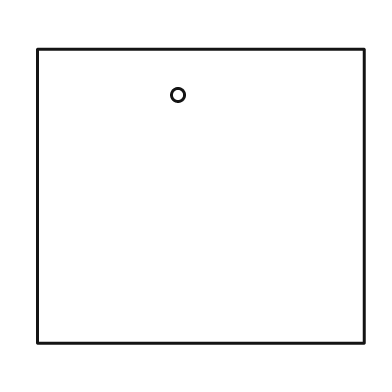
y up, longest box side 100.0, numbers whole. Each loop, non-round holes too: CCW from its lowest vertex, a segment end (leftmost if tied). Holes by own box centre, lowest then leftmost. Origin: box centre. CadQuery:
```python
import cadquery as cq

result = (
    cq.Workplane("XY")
    .moveTo(-50.0, -45.0)
    .lineTo(50.0, -45.0)
    .lineTo(50.0, 45.0)
    .lineTo(-50.0, 45.0)
    .close()
    .moveTo(-7.0, 31.0)
    .circle(2.0)
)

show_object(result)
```